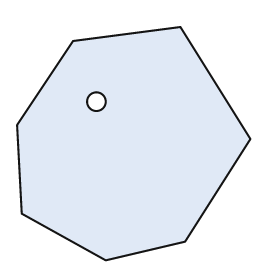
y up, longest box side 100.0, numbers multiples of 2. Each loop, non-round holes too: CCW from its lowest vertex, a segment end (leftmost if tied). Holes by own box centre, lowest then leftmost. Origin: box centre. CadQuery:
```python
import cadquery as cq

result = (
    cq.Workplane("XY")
    .moveTo(-12.0, -50.0)
    .lineTo(22.0, -42.0)
    .lineTo(50.0, 2.0)
    .lineTo(20.0, 50.0)
    .lineTo(-26.0, 44.0)
    .lineTo(-50.0, 8.0)
    .lineTo(-48.0, -30.0)
    .close()
    .moveTo(-16.0, 18.0)
    .circle(4.0)
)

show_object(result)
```